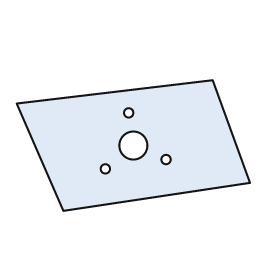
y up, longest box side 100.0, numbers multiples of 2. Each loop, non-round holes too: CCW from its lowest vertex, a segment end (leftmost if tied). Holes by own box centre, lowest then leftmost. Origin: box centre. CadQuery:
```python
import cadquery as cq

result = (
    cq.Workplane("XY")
    .moveTo(-30.0, -28.0)
    .lineTo(50.0, -16.0)
    .lineTo(34.0, 28.0)
    .lineTo(-50.0, 18.0)
    .close()
    .moveTo(-12.0, -10.0)
    .circle(2.0)
    .moveTo(14.0, -6.0)
    .circle(2.0)
    .moveTo(0.0, 0.0)
    .circle(6.0)
    .moveTo(-2.0, 14.0)
    .circle(2.0)
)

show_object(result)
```